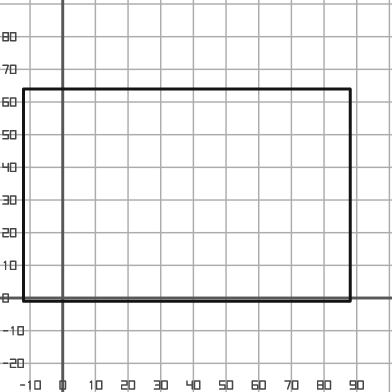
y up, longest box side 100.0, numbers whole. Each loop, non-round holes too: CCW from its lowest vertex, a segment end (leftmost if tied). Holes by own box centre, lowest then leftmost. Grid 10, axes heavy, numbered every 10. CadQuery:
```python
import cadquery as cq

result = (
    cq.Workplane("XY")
    .moveTo(-12.0, -1.0)
    .lineTo(88.0, -1.0)
    .lineTo(88.0, 64.0)
    .lineTo(-12.0, 64.0)
    .close()
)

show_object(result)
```